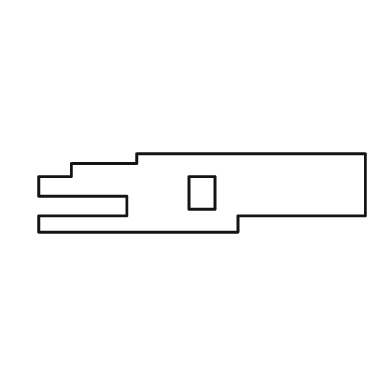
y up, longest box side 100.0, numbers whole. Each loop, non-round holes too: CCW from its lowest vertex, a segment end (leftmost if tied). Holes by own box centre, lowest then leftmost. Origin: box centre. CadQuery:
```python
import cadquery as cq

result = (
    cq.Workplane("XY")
    .moveTo(-50.0, -12.0)
    .lineTo(11.0, -12.0)
    .lineTo(11.0, -7.0)
    .lineTo(50.0, -7.0)
    .lineTo(50.0, 12.0)
    .lineTo(-20.0, 12.0)
    .lineTo(-20.0, 9.0)
    .lineTo(-40.0, 9.0)
    .lineTo(-40.0, 5.0)
    .lineTo(-50.0, 5.0)
    .lineTo(-50.0, -1.0)
    .lineTo(-23.0, -1.0)
    .lineTo(-23.0, -7.0)
    .lineTo(-50.0, -7.0)
    .close()
    .moveTo(-4.0, -5.0)
    .lineTo(4.0, -5.0)
    .lineTo(4.0, 5.0)
    .lineTo(-4.0, 5.0)
    .close()
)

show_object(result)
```